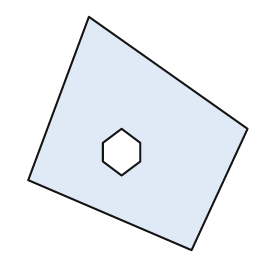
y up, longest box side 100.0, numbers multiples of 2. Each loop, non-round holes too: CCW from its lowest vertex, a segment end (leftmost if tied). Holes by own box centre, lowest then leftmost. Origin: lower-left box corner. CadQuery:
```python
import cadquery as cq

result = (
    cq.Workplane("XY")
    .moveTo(70.0, 0.0)
    .lineTo(94.0, 52.0)
    .lineTo(26.0, 100.0)
    .lineTo(0.0, 30.0)
    .close()
    .moveTo(40.0, 32.0)
    .lineTo(48.0, 38.0)
    .lineTo(48.0, 46.0)
    .lineTo(40.0, 52.0)
    .lineTo(32.0, 46.0)
    .lineTo(32.0, 38.0)
    .close()
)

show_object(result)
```